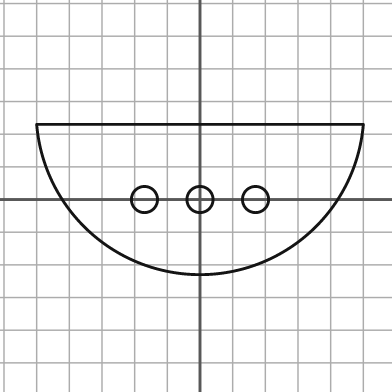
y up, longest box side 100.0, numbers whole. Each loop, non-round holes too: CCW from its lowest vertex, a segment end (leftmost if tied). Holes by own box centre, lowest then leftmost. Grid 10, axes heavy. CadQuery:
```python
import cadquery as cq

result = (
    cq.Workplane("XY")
    .moveTo(-50.0, 23.0)
    .threePointArc((0.0, -23.0), (50.0, 23.0))
    .close()
    .moveTo(-17.0, 0.0)
    .circle(4.0)
    .moveTo(0.0, 0.0)
    .circle(4.0)
    .moveTo(17.0, 0.0)
    .circle(4.0)
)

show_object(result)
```